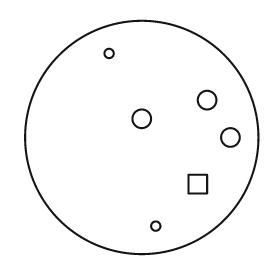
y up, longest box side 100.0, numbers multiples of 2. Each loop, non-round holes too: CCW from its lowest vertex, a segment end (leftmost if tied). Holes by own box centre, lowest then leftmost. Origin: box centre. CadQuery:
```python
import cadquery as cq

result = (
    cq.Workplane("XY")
    .moveTo(0.0, 0.0)
    .circle(50.0)
    .moveTo(6.0, -38.0)
    .circle(2.0)
    .moveTo(20.0, -24.0)
    .lineTo(28.0, -24.0)
    .lineTo(28.0, -16.0)
    .lineTo(20.0, -16.0)
    .close()
    .moveTo(38.0, 0.0)
    .circle(4.0)
    .moveTo(0.0, 8.0)
    .circle(4.0)
    .moveTo(28.0, 16.0)
    .circle(4.0)
    .moveTo(-14.0, 36.0)
    .circle(2.0)
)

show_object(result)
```